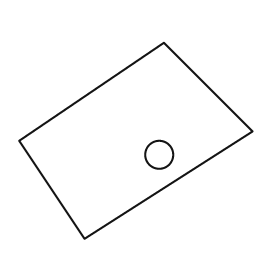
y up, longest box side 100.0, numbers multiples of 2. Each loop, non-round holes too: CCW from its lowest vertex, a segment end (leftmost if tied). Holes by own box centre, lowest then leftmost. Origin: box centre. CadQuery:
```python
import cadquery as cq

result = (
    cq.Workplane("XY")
    .moveTo(-22.0, -42.0)
    .lineTo(50.0, 4.0)
    .lineTo(12.0, 42.0)
    .lineTo(-50.0, 0.0)
    .close()
    .moveTo(10.0, -6.0)
    .circle(6.0)
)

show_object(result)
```